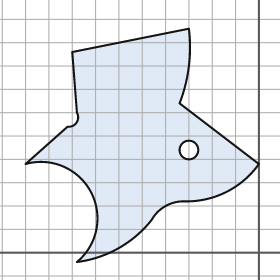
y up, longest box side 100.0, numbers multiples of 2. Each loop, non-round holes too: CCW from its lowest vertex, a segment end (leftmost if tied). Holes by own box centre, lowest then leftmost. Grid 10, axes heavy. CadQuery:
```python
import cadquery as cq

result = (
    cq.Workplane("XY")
    .moveTo(-78.0, -4.0)
    .threePointArc((-60.0, 2.0), (-46.0, 14.0))
    .threePointArc((-40.0, 20.0), (-32.0, 22.0))
    .threePointArc((-14.0, 26.0), (0.0, 38.0))
    .lineTo(-34.0, 64.0)
    .threePointArc((-30.0, 80.0), (-30.0, 96.0))
    .lineTo(-80.0, 86.0)
    .lineTo(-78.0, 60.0)
    .threePointArc((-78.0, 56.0), (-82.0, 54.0))
    .lineTo(-100.0, 38.0)
    .threePointArc((-72.0, 26.0), (-78.0, -4.0))
    .close()
    .moveTo(-30.0, 44.0)
    .circle(4.0)
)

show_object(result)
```